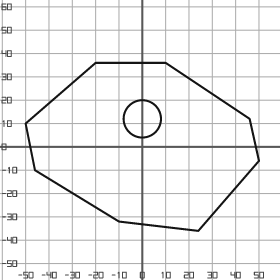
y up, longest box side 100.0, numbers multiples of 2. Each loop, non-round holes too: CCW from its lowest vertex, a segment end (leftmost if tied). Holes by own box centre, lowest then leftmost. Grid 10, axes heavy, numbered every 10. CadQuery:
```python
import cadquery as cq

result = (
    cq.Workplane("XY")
    .moveTo(24.0, -36.0)
    .lineTo(50.0, -6.0)
    .lineTo(46.0, 12.0)
    .lineTo(10.0, 36.0)
    .lineTo(-20.0, 36.0)
    .lineTo(-50.0, 10.0)
    .lineTo(-46.0, -10.0)
    .lineTo(-10.0, -32.0)
    .close()
    .moveTo(0.0, 12.0)
    .circle(8.0)
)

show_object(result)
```